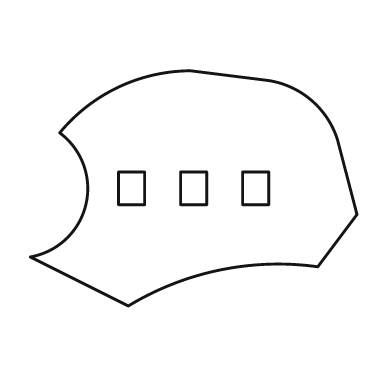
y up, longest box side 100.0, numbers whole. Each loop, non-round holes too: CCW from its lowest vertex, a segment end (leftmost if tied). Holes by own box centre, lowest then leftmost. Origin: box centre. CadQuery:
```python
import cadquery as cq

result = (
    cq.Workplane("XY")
    .moveTo(-20.0, -36.0)
    .threePointArc((8.0, -25.0), (38.0, -24.0))
    .lineTo(50.0, -8.0)
    .lineTo(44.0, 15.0)
    .threePointArc((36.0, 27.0), (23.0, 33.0))
    .lineTo(-1.0, 36.0)
    .threePointArc((-23.0, 31.0), (-41.0, 17.0))
    .threePointArc((-33.0, -5.0), (-50.0, -21.0))
    .close()
    .moveTo(-23.0, -5.0)
    .lineTo(-15.0, -5.0)
    .lineTo(-15.0, 5.0)
    .lineTo(-23.0, 5.0)
    .close()
    .moveTo(-4.0, -5.0)
    .lineTo(4.0, -5.0)
    .lineTo(4.0, 5.0)
    .lineTo(-4.0, 5.0)
    .close()
    .moveTo(15.0, -5.0)
    .lineTo(23.0, -5.0)
    .lineTo(23.0, 5.0)
    .lineTo(15.0, 5.0)
    .close()
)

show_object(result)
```